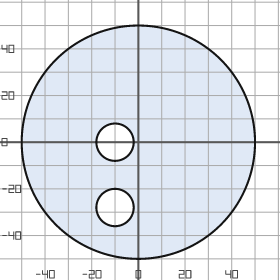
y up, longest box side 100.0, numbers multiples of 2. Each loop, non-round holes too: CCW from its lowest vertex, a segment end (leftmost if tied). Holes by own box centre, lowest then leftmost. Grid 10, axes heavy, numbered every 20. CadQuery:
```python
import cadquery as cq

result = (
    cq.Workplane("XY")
    .moveTo(0.0, 0.0)
    .circle(50.0)
    .moveTo(-10.0, -28.0)
    .circle(8.0)
    .moveTo(-10.0, 0.0)
    .circle(8.0)
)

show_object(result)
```